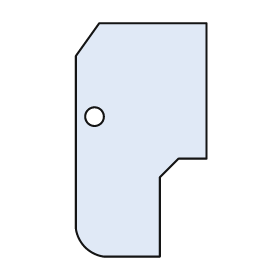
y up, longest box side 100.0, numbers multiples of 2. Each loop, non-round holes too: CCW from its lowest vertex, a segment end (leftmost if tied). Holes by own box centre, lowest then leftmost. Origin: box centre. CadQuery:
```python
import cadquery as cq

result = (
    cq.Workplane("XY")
    .moveTo(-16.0, -50.0)
    .lineTo(8.0, -50.0)
    .lineTo(8.0, -16.0)
    .lineTo(16.0, -8.0)
    .lineTo(28.0, -8.0)
    .lineTo(28.0, 50.0)
    .lineTo(-18.0, 50.0)
    .lineTo(-28.0, 36.0)
    .lineTo(-28.0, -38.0)
    .threePointArc((-24.0, -46.0), (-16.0, -50.0))
    .close()
    .moveTo(-20.0, 10.0)
    .circle(4.0)
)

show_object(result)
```